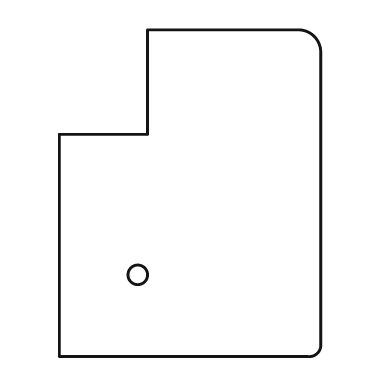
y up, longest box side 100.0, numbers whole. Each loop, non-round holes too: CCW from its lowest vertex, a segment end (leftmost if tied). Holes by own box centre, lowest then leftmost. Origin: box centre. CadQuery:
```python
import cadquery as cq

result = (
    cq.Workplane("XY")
    .moveTo(-40.0, -50.0)
    .lineTo(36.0, -50.0)
    .threePointArc((39.0, -49.0), (40.0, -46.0))
    .lineTo(40.0, 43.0)
    .threePointArc((38.0, 48.0), (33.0, 50.0))
    .lineTo(-13.0, 50.0)
    .lineTo(-13.0, 18.0)
    .lineTo(-40.0, 18.0)
    .close()
    .moveTo(-16.0, -25.0)
    .circle(3.0)
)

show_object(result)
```